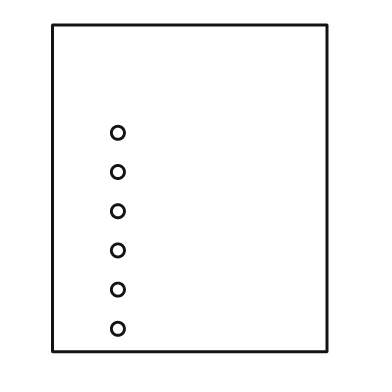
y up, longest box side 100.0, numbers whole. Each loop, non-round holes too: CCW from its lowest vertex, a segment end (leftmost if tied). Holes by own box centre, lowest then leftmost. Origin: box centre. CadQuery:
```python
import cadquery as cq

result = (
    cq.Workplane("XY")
    .moveTo(-42.0, -50.0)
    .lineTo(42.0, -50.0)
    .lineTo(42.0, 50.0)
    .lineTo(-42.0, 50.0)
    .close()
    .moveTo(-22.0, -43.0)
    .circle(2.0)
    .moveTo(-22.0, -31.0)
    .circle(2.0)
    .moveTo(-22.0, -19.0)
    .circle(2.0)
    .moveTo(-22.0, -7.0)
    .circle(2.0)
    .moveTo(-22.0, 5.0)
    .circle(2.0)
    .moveTo(-22.0, 17.0)
    .circle(2.0)
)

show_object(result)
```